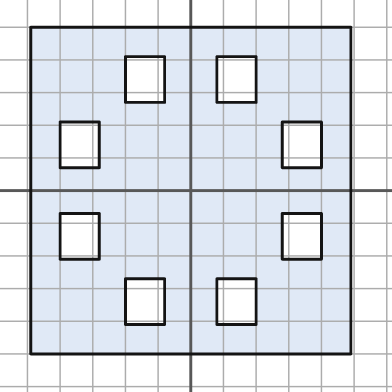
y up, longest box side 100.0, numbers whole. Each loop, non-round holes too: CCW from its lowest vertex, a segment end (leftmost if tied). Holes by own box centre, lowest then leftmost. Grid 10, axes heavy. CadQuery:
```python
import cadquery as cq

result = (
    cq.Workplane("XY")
    .moveTo(-49.0, -50.0)
    .lineTo(49.0, -50.0)
    .lineTo(49.0, 50.0)
    .lineTo(-49.0, 50.0)
    .close()
    .moveTo(-20.0, -41.0)
    .lineTo(-8.0, -41.0)
    .lineTo(-8.0, -27.0)
    .lineTo(-20.0, -27.0)
    .close()
    .moveTo(8.0, -41.0)
    .lineTo(20.0, -41.0)
    .lineTo(20.0, -27.0)
    .lineTo(8.0, -27.0)
    .close()
    .moveTo(-40.0, -21.0)
    .lineTo(-28.0, -21.0)
    .lineTo(-28.0, -7.0)
    .lineTo(-40.0, -7.0)
    .close()
    .moveTo(28.0, -21.0)
    .lineTo(40.0, -21.0)
    .lineTo(40.0, -7.0)
    .lineTo(28.0, -7.0)
    .close()
    .moveTo(-40.0, 7.0)
    .lineTo(-28.0, 7.0)
    .lineTo(-28.0, 21.0)
    .lineTo(-40.0, 21.0)
    .close()
    .moveTo(28.0, 7.0)
    .lineTo(40.0, 7.0)
    .lineTo(40.0, 21.0)
    .lineTo(28.0, 21.0)
    .close()
    .moveTo(-20.0, 27.0)
    .lineTo(-8.0, 27.0)
    .lineTo(-8.0, 41.0)
    .lineTo(-20.0, 41.0)
    .close()
    .moveTo(8.0, 27.0)
    .lineTo(20.0, 27.0)
    .lineTo(20.0, 41.0)
    .lineTo(8.0, 41.0)
    .close()
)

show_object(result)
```